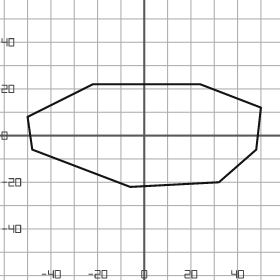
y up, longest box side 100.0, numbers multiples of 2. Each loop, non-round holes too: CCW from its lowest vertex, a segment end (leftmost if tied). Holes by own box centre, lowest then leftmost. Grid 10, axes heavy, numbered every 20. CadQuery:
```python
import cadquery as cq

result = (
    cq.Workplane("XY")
    .moveTo(-6.0, -22.0)
    .lineTo(32.0, -20.0)
    .lineTo(48.0, -6.0)
    .lineTo(50.0, 12.0)
    .lineTo(24.0, 22.0)
    .lineTo(-22.0, 22.0)
    .lineTo(-50.0, 8.0)
    .lineTo(-48.0, -6.0)
    .close()
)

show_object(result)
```